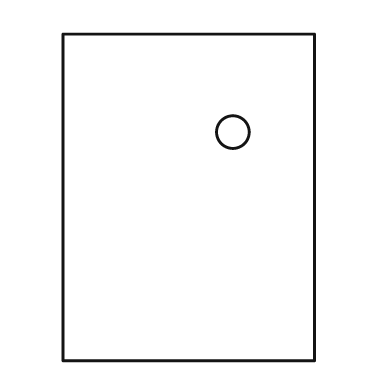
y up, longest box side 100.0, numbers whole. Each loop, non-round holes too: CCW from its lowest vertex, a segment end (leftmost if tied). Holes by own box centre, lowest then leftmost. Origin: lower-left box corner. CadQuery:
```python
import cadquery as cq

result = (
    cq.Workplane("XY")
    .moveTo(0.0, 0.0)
    .lineTo(77.0, 0.0)
    .lineTo(77.0, 100.0)
    .lineTo(0.0, 100.0)
    .close()
    .moveTo(52.0, 70.0)
    .circle(5.0)
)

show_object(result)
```